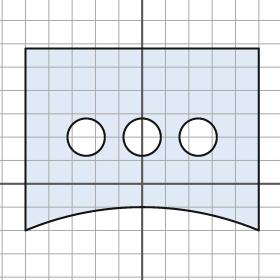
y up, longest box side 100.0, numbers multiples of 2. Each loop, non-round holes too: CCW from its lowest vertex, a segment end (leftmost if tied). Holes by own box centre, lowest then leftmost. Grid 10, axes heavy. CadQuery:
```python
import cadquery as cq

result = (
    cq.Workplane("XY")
    .moveTo(-50.0, -20.0)
    .threePointArc((0.0, -10.0), (50.0, -20.0))
    .lineTo(50.0, 58.0)
    .lineTo(-50.0, 58.0)
    .close()
    .moveTo(-24.0, 20.0)
    .circle(8.0)
    .moveTo(0.0, 20.0)
    .circle(8.0)
    .moveTo(24.0, 20.0)
    .circle(8.0)
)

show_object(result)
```